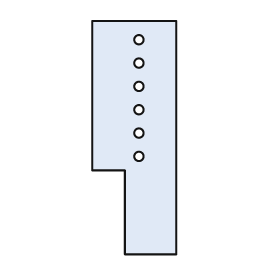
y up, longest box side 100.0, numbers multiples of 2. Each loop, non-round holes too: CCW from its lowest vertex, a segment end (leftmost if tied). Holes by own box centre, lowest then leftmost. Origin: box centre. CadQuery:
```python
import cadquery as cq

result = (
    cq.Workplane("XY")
    .moveTo(-4.0, -50.0)
    .lineTo(18.0, -50.0)
    .lineTo(18.0, 50.0)
    .lineTo(-18.0, 50.0)
    .lineTo(-18.0, -14.0)
    .lineTo(-4.0, -14.0)
    .close()
    .moveTo(2.0, -8.0)
    .circle(2.0)
    .moveTo(2.0, 2.0)
    .circle(2.0)
    .moveTo(2.0, 12.0)
    .circle(2.0)
    .moveTo(2.0, 22.0)
    .circle(2.0)
    .moveTo(2.0, 32.0)
    .circle(2.0)
    .moveTo(2.0, 42.0)
    .circle(2.0)
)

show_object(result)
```